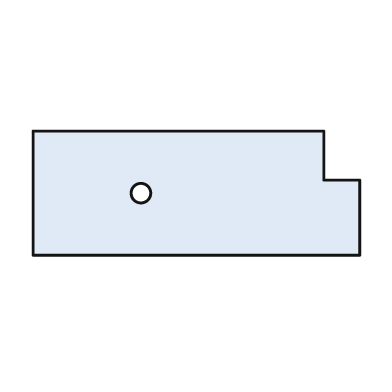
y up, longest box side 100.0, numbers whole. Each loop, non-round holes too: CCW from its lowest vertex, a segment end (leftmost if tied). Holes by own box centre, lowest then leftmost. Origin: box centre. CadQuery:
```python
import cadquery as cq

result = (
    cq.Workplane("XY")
    .moveTo(-50.0, -19.0)
    .lineTo(50.0, -19.0)
    .lineTo(50.0, 4.0)
    .lineTo(39.0, 4.0)
    .lineTo(39.0, 19.0)
    .lineTo(-50.0, 19.0)
    .close()
    .moveTo(-17.0, 0.0)
    .circle(3.0)
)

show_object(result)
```